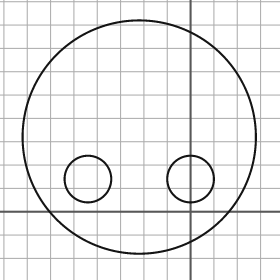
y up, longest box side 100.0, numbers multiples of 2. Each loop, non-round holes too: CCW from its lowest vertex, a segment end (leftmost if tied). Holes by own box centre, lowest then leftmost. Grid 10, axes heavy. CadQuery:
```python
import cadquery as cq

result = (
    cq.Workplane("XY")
    .moveTo(-22.0, 32.0)
    .circle(50.0)
    .moveTo(-44.0, 14.0)
    .circle(10.0)
    .moveTo(0.0, 14.0)
    .circle(10.0)
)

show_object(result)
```